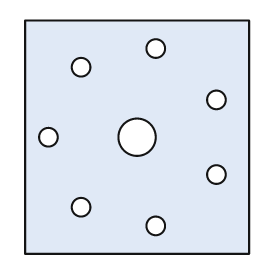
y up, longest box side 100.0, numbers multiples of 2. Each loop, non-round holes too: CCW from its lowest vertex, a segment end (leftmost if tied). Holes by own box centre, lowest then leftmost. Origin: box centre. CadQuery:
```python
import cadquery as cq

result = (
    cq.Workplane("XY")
    .moveTo(-48.0, -50.0)
    .lineTo(48.0, -50.0)
    .lineTo(48.0, 50.0)
    .lineTo(-48.0, 50.0)
    .close()
    .moveTo(8.0, -38.0)
    .circle(4.0)
    .moveTo(-24.0, -30.0)
    .circle(4.0)
    .moveTo(34.0, -16.0)
    .circle(4.0)
    .moveTo(-38.0, 0.0)
    .circle(4.0)
    .moveTo(0.0, 0.0)
    .circle(8.0)
    .moveTo(34.0, 16.0)
    .circle(4.0)
    .moveTo(-24.0, 30.0)
    .circle(4.0)
    .moveTo(8.0, 38.0)
    .circle(4.0)
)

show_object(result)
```